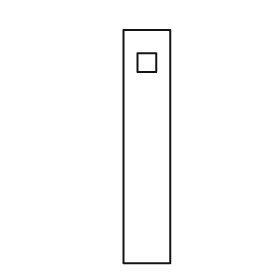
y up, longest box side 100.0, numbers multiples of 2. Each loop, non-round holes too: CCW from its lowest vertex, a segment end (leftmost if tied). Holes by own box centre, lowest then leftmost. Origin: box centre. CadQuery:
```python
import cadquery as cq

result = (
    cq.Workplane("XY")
    .moveTo(-10.0, -50.0)
    .lineTo(10.0, -50.0)
    .lineTo(10.0, 50.0)
    .lineTo(-10.0, 50.0)
    .close()
    .moveTo(-4.0, 32.0)
    .lineTo(4.0, 32.0)
    .lineTo(4.0, 40.0)
    .lineTo(-4.0, 40.0)
    .close()
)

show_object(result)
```